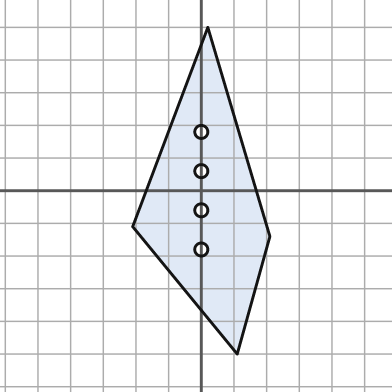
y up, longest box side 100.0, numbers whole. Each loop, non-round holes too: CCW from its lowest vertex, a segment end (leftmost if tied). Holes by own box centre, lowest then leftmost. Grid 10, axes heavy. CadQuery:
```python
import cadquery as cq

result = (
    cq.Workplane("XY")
    .moveTo(11.0, -50.0)
    .lineTo(21.0, -14.0)
    .lineTo(2.0, 50.0)
    .lineTo(-21.0, -11.0)
    .close()
    .moveTo(0.0, -18.0)
    .circle(2.0)
    .moveTo(0.0, -6.0)
    .circle(2.0)
    .moveTo(0.0, 6.0)
    .circle(2.0)
    .moveTo(0.0, 18.0)
    .circle(2.0)
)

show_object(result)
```